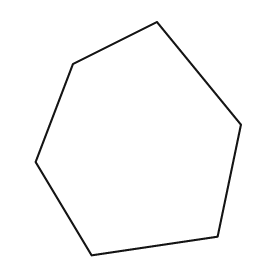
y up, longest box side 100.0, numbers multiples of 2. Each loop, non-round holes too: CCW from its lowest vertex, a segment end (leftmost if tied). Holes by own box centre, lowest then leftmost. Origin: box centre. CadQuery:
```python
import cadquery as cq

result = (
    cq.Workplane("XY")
    .moveTo(-20.0, -50.0)
    .lineTo(34.0, -42.0)
    .lineTo(44.0, 6.0)
    .lineTo(8.0, 50.0)
    .lineTo(-28.0, 32.0)
    .lineTo(-44.0, -10.0)
    .close()
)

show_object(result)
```